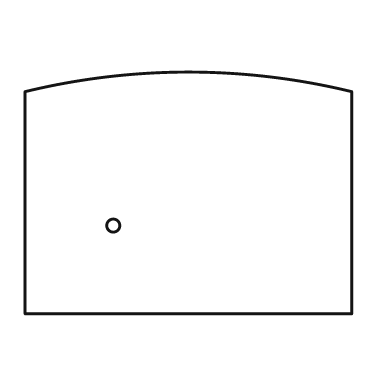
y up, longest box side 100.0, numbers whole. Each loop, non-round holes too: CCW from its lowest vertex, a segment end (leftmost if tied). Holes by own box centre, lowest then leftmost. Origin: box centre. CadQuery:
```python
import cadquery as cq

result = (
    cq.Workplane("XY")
    .moveTo(-50.0, -37.0)
    .lineTo(50.0, -37.0)
    .lineTo(50.0, 31.0)
    .threePointArc((0.0, 37.0), (-50.0, 31.0))
    .close()
    .moveTo(-23.0, -10.0)
    .circle(2.0)
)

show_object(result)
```